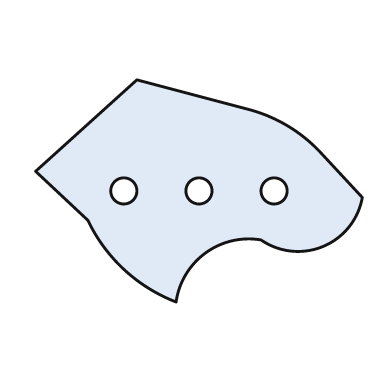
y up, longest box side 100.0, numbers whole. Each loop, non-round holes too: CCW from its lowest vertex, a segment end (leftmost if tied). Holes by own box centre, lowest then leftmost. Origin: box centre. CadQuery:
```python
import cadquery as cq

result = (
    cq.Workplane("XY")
    .moveTo(-7.0, -34.0)
    .threePointArc((2.0, -19.0), (19.0, -15.0))
    .threePointArc((38.0, -17.0), (50.0, -2.0))
    .lineTo(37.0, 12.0)
    .threePointArc((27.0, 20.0), (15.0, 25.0))
    .lineTo(-19.0, 34.0)
    .lineTo(-50.0, 6.0)
    .lineTo(-34.0, -9.0)
    .threePointArc((-23.0, -24.0), (-7.0, -34.0))
    .close()
    .moveTo(-23.0, 0.0)
    .circle(4.0)
    .moveTo(0.0, 0.0)
    .circle(4.0)
    .moveTo(23.0, 0.0)
    .circle(4.0)
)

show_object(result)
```